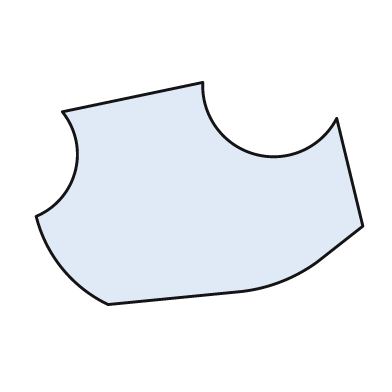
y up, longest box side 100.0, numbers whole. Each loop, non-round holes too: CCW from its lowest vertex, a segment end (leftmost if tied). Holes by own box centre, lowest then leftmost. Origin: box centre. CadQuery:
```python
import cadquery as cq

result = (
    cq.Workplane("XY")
    .moveTo(-28.0, -34.0)
    .lineTo(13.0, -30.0)
    .threePointArc((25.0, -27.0), (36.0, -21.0))
    .lineTo(50.0, -10.0)
    .lineTo(42.0, 23.0)
    .threePointArc((17.0, 12.0), (1.0, 34.0))
    .lineTo(-42.0, 25.0)
    .threePointArc((-38.0, 7.0), (-50.0, -7.0))
    .threePointArc((-42.0, -23.0), (-28.0, -34.0))
    .close()
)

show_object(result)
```